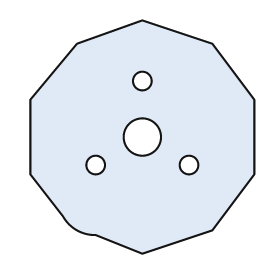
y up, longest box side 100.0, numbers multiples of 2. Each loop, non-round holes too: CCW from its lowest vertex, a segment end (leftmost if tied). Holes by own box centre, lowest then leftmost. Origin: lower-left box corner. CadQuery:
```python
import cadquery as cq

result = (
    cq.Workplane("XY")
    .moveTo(48.0, 0.0)
    .lineTo(78.0, 10.0)
    .lineTo(96.0, 34.0)
    .lineTo(96.0, 66.0)
    .lineTo(78.0, 90.0)
    .lineTo(48.0, 100.0)
    .lineTo(20.0, 90.0)
    .lineTo(0.0, 66.0)
    .lineTo(0.0, 34.0)
    .lineTo(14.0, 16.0)
    .threePointArc((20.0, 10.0), (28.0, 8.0))
    .close()
    .moveTo(28.0, 38.0)
    .circle(4.0)
    .moveTo(68.0, 38.0)
    .circle(4.0)
    .moveTo(48.0, 50.0)
    .circle(8.0)
    .moveTo(48.0, 74.0)
    .circle(4.0)
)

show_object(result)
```